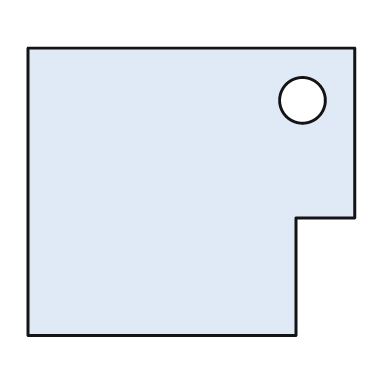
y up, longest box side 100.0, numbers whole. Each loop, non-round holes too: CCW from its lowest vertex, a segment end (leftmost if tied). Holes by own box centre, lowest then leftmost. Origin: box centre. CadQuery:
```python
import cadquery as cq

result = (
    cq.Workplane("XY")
    .moveTo(-50.0, -44.0)
    .lineTo(32.0, -44.0)
    .lineTo(32.0, -8.0)
    .lineTo(50.0, -8.0)
    .lineTo(50.0, 44.0)
    .lineTo(-50.0, 44.0)
    .close()
    .moveTo(34.0, 28.0)
    .circle(7.0)
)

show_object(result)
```